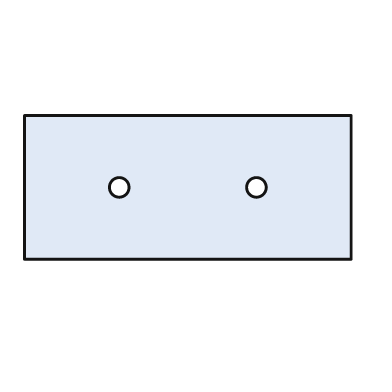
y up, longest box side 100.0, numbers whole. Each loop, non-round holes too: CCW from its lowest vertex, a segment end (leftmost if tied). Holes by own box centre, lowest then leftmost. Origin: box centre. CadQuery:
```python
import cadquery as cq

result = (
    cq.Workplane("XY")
    .moveTo(-50.0, -22.0)
    .lineTo(50.0, -22.0)
    .lineTo(50.0, 22.0)
    .lineTo(-50.0, 22.0)
    .close()
    .moveTo(-21.0, 0.0)
    .circle(3.0)
    .moveTo(21.0, 0.0)
    .circle(3.0)
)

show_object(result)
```